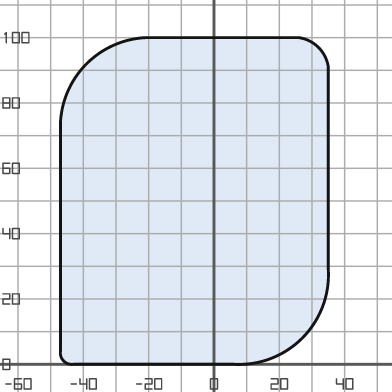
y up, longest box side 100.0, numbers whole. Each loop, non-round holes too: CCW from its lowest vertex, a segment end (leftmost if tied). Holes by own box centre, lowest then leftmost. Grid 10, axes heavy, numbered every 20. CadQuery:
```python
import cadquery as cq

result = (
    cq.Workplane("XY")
    .moveTo(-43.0, 0.0)
    .lineTo(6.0, 0.0)
    .threePointArc((27.0, 8.0), (35.0, 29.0))
    .lineTo(35.0, 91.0)
    .threePointArc((32.0, 97.0), (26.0, 100.0))
    .lineTo(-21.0, 100.0)
    .threePointArc((-39.0, 92.0), (-47.0, 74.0))
    .lineTo(-47.0, 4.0)
    .threePointArc((-46.0, 1.0), (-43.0, 0.0))
    .close()
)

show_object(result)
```